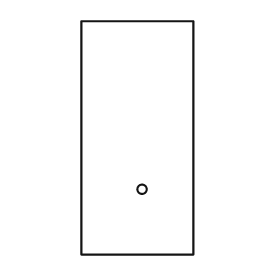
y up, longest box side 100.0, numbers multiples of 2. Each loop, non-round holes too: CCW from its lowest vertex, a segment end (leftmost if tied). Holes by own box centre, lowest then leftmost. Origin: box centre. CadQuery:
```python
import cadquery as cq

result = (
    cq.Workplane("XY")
    .moveTo(-24.0, -50.0)
    .lineTo(24.0, -50.0)
    .lineTo(24.0, 50.0)
    .lineTo(-24.0, 50.0)
    .close()
    .moveTo(2.0, -22.0)
    .circle(2.0)
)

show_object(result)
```